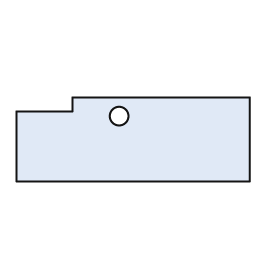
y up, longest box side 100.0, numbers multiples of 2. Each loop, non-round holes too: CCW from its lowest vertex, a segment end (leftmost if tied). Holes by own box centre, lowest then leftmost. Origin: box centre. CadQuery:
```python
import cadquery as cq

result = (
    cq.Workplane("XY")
    .moveTo(-50.0, -18.0)
    .lineTo(50.0, -18.0)
    .lineTo(50.0, 18.0)
    .lineTo(-26.0, 18.0)
    .lineTo(-26.0, 12.0)
    .lineTo(-50.0, 12.0)
    .close()
    .moveTo(-6.0, 10.0)
    .circle(4.0)
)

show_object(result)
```